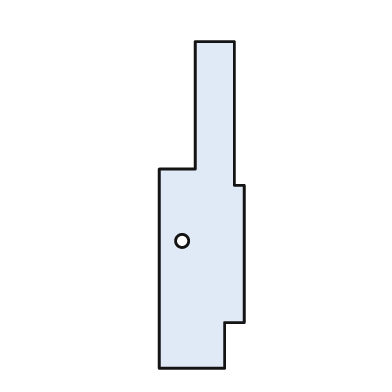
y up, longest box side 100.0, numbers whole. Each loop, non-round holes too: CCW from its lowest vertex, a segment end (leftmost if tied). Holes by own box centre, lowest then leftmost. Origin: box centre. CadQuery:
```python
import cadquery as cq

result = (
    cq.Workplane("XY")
    .moveTo(-13.0, -50.0)
    .lineTo(7.0, -50.0)
    .lineTo(7.0, -36.0)
    .lineTo(13.0, -36.0)
    .lineTo(13.0, 6.0)
    .lineTo(10.0, 6.0)
    .lineTo(10.0, 50.0)
    .lineTo(-2.0, 50.0)
    .lineTo(-2.0, 11.0)
    .lineTo(-13.0, 11.0)
    .close()
    .moveTo(-6.0, -11.0)
    .circle(2.0)
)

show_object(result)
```